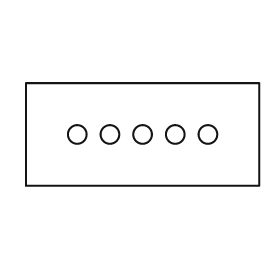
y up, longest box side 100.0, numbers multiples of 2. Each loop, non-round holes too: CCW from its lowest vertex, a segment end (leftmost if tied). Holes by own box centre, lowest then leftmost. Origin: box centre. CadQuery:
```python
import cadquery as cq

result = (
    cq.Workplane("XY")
    .moveTo(-50.0, -22.0)
    .lineTo(50.0, -22.0)
    .lineTo(50.0, 22.0)
    .lineTo(-50.0, 22.0)
    .close()
    .moveTo(-28.0, 0.0)
    .circle(4.0)
    .moveTo(-14.0, 0.0)
    .circle(4.0)
    .moveTo(0.0, 0.0)
    .circle(4.0)
    .moveTo(14.0, 0.0)
    .circle(4.0)
    .moveTo(28.0, 0.0)
    .circle(4.0)
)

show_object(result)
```